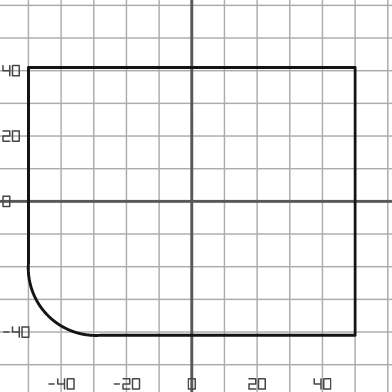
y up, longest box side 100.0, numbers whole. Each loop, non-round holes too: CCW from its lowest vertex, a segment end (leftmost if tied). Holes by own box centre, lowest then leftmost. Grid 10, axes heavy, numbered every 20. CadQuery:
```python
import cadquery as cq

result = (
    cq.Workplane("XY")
    .moveTo(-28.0, -41.0)
    .lineTo(50.0, -41.0)
    .lineTo(50.0, 41.0)
    .lineTo(-50.0, 41.0)
    .lineTo(-50.0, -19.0)
    .threePointArc((-44.0, -35.0), (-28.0, -41.0))
    .close()
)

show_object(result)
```